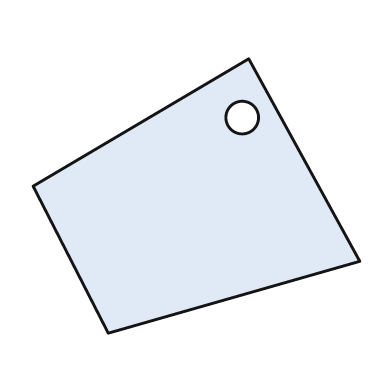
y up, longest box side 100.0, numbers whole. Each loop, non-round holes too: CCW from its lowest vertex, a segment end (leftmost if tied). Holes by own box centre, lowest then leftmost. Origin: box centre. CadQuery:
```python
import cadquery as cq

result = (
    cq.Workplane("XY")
    .moveTo(-27.0, -42.0)
    .lineTo(50.0, -20.0)
    .lineTo(16.0, 42.0)
    .lineTo(-50.0, 3.0)
    .close()
    .moveTo(14.0, 24.0)
    .circle(5.0)
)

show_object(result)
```